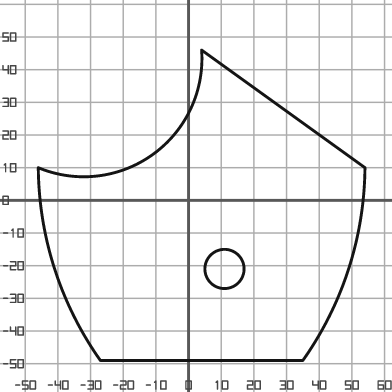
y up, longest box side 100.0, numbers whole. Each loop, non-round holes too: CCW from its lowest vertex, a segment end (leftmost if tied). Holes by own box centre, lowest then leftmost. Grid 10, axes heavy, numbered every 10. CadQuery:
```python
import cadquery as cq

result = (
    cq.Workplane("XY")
    .moveTo(-27.0, -49.0)
    .lineTo(35.0, -49.0)
    .threePointArc((49.0, -21.0), (54.0, 10.0))
    .lineTo(4.0, 46.0)
    .threePointArc((-11.0, 14.0), (-46.0, 10.0))
    .threePointArc((-41.0, -21.0), (-27.0, -49.0))
    .close()
    .moveTo(11.0, -21.0)
    .circle(6.0)
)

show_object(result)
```